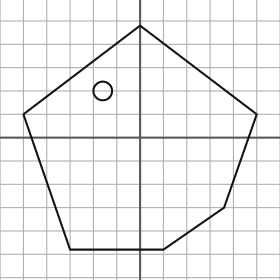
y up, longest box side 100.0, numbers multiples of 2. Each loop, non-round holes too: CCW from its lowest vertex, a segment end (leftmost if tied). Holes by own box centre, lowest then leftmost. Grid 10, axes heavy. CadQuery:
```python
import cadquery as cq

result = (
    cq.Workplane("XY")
    .moveTo(-30.0, -48.0)
    .lineTo(10.0, -48.0)
    .lineTo(36.0, -30.0)
    .lineTo(50.0, 10.0)
    .lineTo(0.0, 48.0)
    .lineTo(-50.0, 10.0)
    .close()
    .moveTo(-16.0, 20.0)
    .circle(4.0)
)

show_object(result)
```